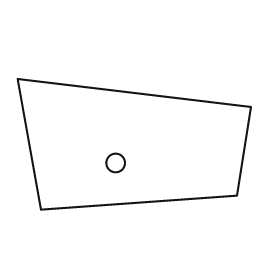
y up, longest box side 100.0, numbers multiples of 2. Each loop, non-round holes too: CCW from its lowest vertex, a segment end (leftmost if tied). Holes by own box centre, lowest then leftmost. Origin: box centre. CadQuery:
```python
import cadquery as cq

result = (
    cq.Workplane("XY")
    .moveTo(-40.0, -28.0)
    .lineTo(44.0, -22.0)
    .lineTo(50.0, 16.0)
    .lineTo(-50.0, 28.0)
    .close()
    .moveTo(-8.0, -8.0)
    .circle(4.0)
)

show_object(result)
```